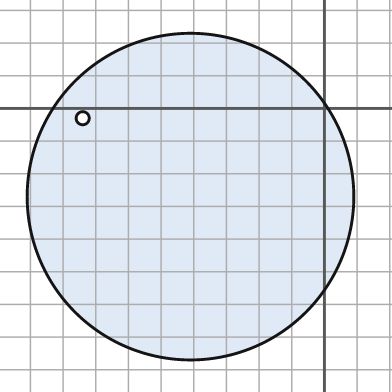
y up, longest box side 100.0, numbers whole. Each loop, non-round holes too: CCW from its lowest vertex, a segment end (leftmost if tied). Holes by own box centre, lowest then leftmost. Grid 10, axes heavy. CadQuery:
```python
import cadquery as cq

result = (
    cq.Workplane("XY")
    .moveTo(-41.0, -27.0)
    .circle(50.0)
    .moveTo(-74.0, -3.0)
    .circle(2.0)
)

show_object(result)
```